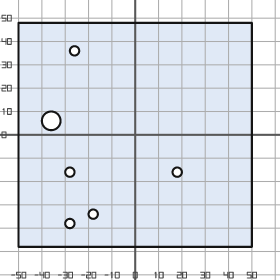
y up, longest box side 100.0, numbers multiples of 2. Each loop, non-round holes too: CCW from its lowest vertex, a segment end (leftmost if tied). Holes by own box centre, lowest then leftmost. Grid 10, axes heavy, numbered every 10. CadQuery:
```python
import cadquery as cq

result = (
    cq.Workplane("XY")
    .moveTo(-50.0, -48.0)
    .lineTo(50.0, -48.0)
    .lineTo(50.0, 48.0)
    .lineTo(-50.0, 48.0)
    .close()
    .moveTo(-28.0, -38.0)
    .circle(2.0)
    .moveTo(-18.0, -34.0)
    .circle(2.0)
    .moveTo(-28.0, -16.0)
    .circle(2.0)
    .moveTo(18.0, -16.0)
    .circle(2.0)
    .moveTo(-36.0, 6.0)
    .circle(4.0)
    .moveTo(-26.0, 36.0)
    .circle(2.0)
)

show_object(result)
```